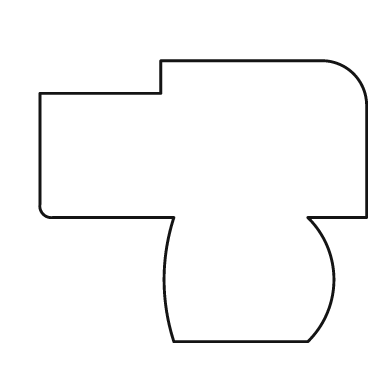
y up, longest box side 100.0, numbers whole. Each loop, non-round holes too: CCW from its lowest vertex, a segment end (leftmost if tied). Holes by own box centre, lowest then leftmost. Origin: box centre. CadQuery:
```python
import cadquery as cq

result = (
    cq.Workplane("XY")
    .moveTo(-9.0, -43.0)
    .lineTo(32.0, -43.0)
    .threePointArc((40.0, -24.0), (32.0, -5.0))
    .lineTo(50.0, -5.0)
    .lineTo(50.0, 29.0)
    .threePointArc((46.0, 39.0), (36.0, 43.0))
    .lineTo(-13.0, 43.0)
    .lineTo(-13.0, 33.0)
    .lineTo(-50.0, 33.0)
    .lineTo(-50.0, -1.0)
    .threePointArc((-49.0, -4.0), (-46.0, -5.0))
    .lineTo(-9.0, -5.0)
    .threePointArc((-12.0, -24.0), (-9.0, -43.0))
    .close()
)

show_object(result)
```